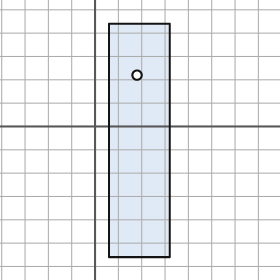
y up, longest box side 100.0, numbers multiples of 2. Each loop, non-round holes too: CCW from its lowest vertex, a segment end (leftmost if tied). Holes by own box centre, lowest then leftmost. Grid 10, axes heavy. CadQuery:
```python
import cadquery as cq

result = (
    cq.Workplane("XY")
    .moveTo(6.0, -56.0)
    .lineTo(32.0, -56.0)
    .lineTo(32.0, 44.0)
    .lineTo(6.0, 44.0)
    .close()
    .moveTo(18.0, 22.0)
    .circle(2.0)
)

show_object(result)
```